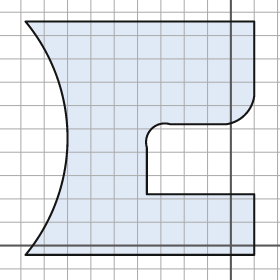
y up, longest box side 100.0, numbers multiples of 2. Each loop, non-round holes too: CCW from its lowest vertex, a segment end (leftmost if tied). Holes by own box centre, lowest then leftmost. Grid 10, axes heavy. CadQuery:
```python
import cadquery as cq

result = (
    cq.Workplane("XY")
    .moveTo(-88.0, -4.0)
    .lineTo(10.0, -4.0)
    .lineTo(10.0, 22.0)
    .lineTo(-36.0, 22.0)
    .lineTo(-36.0, 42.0)
    .threePointArc((-34.0, 50.0), (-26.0, 52.0))
    .lineTo(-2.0, 52.0)
    .threePointArc((6.0, 56.0), (10.0, 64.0))
    .lineTo(10.0, 96.0)
    .lineTo(-88.0, 96.0)
    .threePointArc((-70.0, 46.0), (-88.0, -4.0))
    .close()
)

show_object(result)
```